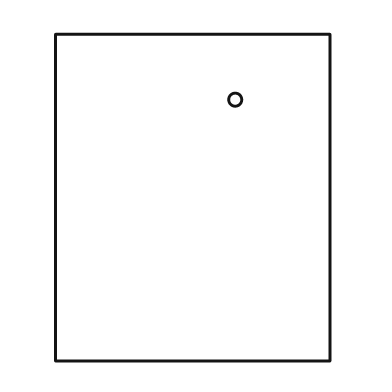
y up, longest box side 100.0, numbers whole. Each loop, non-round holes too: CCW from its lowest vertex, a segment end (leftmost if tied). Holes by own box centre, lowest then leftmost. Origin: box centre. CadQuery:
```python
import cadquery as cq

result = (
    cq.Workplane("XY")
    .moveTo(-42.0, -50.0)
    .lineTo(42.0, -50.0)
    .lineTo(42.0, 50.0)
    .lineTo(-42.0, 50.0)
    .close()
    .moveTo(13.0, 30.0)
    .circle(2.0)
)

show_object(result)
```